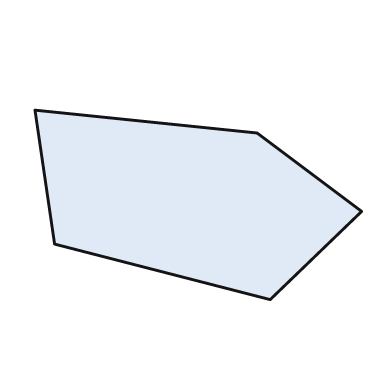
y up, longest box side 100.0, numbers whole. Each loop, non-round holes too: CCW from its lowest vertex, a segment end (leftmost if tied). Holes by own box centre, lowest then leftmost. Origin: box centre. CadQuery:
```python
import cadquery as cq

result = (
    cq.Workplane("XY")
    .moveTo(22.0, -29.0)
    .lineTo(50.0, -2.0)
    .lineTo(18.0, 22.0)
    .lineTo(-50.0, 29.0)
    .lineTo(-44.0, -12.0)
    .close()
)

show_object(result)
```